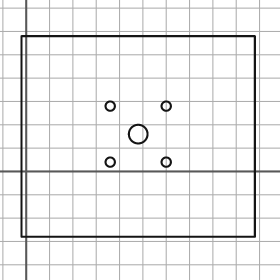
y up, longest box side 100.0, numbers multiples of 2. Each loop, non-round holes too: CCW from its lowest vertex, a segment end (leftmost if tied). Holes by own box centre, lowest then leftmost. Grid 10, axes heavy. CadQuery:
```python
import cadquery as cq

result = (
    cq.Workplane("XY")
    .moveTo(-2.0, -28.0)
    .lineTo(98.0, -28.0)
    .lineTo(98.0, 58.0)
    .lineTo(-2.0, 58.0)
    .close()
    .moveTo(36.0, 4.0)
    .circle(2.0)
    .moveTo(60.0, 4.0)
    .circle(2.0)
    .moveTo(48.0, 16.0)
    .circle(4.0)
    .moveTo(36.0, 28.0)
    .circle(2.0)
    .moveTo(60.0, 28.0)
    .circle(2.0)
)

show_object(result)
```